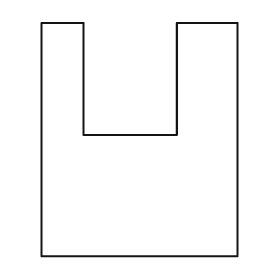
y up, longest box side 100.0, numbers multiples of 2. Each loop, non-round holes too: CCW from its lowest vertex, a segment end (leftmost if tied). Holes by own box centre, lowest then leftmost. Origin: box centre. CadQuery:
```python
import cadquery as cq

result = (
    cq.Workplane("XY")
    .moveTo(-42.0, -50.0)
    .lineTo(42.0, -50.0)
    .lineTo(42.0, 50.0)
    .lineTo(16.0, 50.0)
    .lineTo(16.0, 2.0)
    .lineTo(-24.0, 2.0)
    .lineTo(-24.0, 50.0)
    .lineTo(-42.0, 50.0)
    .close()
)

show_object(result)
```